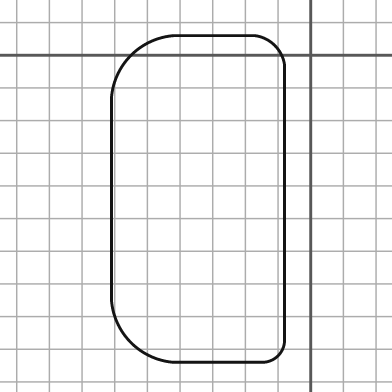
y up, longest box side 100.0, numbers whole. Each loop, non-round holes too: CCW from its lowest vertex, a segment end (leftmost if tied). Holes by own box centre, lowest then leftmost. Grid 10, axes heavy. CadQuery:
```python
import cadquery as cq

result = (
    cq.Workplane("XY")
    .moveTo(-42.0, -94.0)
    .lineTo(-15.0, -94.0)
    .threePointArc((-10.0, -92.0), (-8.0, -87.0))
    .lineTo(-8.0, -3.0)
    .threePointArc((-11.0, 3.0), (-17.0, 6.0))
    .lineTo(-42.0, 6.0)
    .threePointArc((-55.0, 0.0), (-61.0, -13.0))
    .lineTo(-61.0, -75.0)
    .threePointArc((-55.0, -88.0), (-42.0, -94.0))
    .close()
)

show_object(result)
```